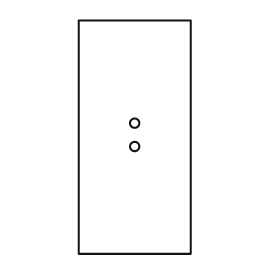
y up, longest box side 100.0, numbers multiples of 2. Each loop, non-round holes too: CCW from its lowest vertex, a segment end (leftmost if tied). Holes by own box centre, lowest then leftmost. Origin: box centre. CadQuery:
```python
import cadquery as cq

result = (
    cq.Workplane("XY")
    .moveTo(-24.0, -50.0)
    .lineTo(24.0, -50.0)
    .lineTo(24.0, 50.0)
    .lineTo(-24.0, 50.0)
    .close()
    .moveTo(0.0, -4.0)
    .circle(2.0)
    .moveTo(0.0, 6.0)
    .circle(2.0)
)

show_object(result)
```